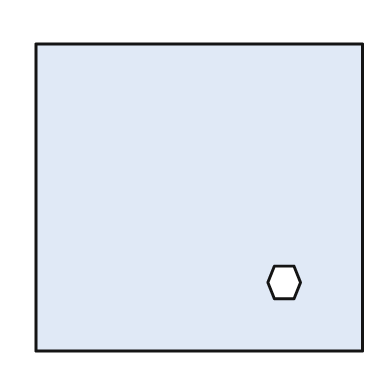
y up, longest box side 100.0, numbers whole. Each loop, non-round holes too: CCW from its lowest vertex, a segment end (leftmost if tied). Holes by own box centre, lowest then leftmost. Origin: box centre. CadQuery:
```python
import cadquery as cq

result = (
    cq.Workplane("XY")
    .moveTo(-50.0, -47.0)
    .lineTo(50.0, -47.0)
    .lineTo(50.0, 47.0)
    .lineTo(-50.0, 47.0)
    .close()
    .moveTo(23.0, -31.0)
    .lineTo(29.0, -31.0)
    .lineTo(31.0, -26.0)
    .lineTo(29.0, -21.0)
    .lineTo(23.0, -21.0)
    .lineTo(21.0, -26.0)
    .close()
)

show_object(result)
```